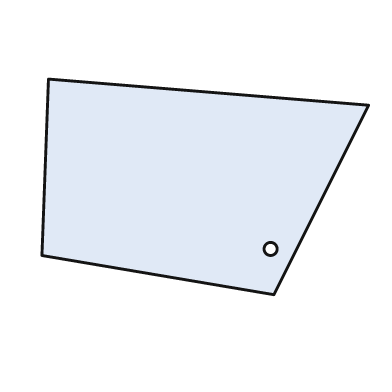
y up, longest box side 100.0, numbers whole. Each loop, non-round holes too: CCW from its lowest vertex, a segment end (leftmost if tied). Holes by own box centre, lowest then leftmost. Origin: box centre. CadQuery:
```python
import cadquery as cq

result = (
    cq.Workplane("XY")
    .moveTo(21.0, -33.0)
    .lineTo(50.0, 25.0)
    .lineTo(-48.0, 33.0)
    .lineTo(-50.0, -21.0)
    .close()
    .moveTo(20.0, -19.0)
    .circle(2.0)
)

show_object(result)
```